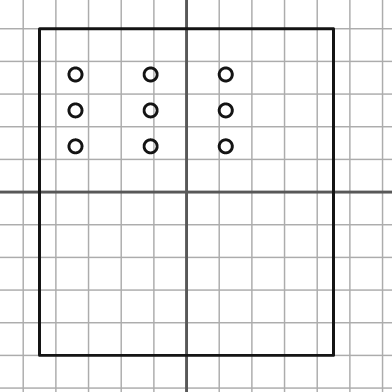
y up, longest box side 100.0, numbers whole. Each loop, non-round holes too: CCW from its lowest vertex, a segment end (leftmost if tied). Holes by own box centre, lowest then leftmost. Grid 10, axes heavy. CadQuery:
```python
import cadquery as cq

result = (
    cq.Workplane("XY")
    .moveTo(-45.0, -50.0)
    .lineTo(45.0, -50.0)
    .lineTo(45.0, 50.0)
    .lineTo(-45.0, 50.0)
    .close()
    .moveTo(-34.0, 14.0)
    .circle(2.0)
    .moveTo(-11.0, 14.0)
    .circle(2.0)
    .moveTo(12.0, 14.0)
    .circle(2.0)
    .moveTo(-34.0, 25.0)
    .circle(2.0)
    .moveTo(-11.0, 25.0)
    .circle(2.0)
    .moveTo(12.0, 25.0)
    .circle(2.0)
    .moveTo(-34.0, 36.0)
    .circle(2.0)
    .moveTo(-11.0, 36.0)
    .circle(2.0)
    .moveTo(12.0, 36.0)
    .circle(2.0)
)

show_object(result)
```